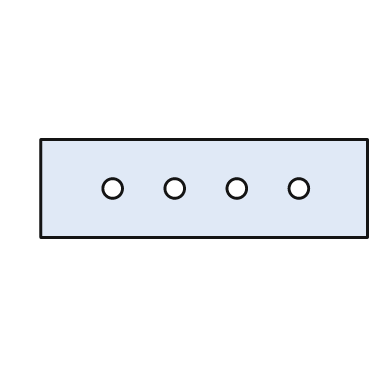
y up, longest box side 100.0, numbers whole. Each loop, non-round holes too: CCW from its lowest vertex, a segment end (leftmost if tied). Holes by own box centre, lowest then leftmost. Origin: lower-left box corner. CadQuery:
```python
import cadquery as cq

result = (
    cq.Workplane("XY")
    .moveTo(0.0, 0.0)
    .lineTo(100.0, 0.0)
    .lineTo(100.0, 30.0)
    .lineTo(0.0, 30.0)
    .close()
    .moveTo(22.0, 15.0)
    .circle(3.0)
    .moveTo(41.0, 15.0)
    .circle(3.0)
    .moveTo(60.0, 15.0)
    .circle(3.0)
    .moveTo(79.0, 15.0)
    .circle(3.0)
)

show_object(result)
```